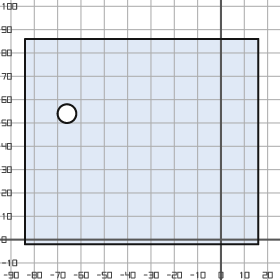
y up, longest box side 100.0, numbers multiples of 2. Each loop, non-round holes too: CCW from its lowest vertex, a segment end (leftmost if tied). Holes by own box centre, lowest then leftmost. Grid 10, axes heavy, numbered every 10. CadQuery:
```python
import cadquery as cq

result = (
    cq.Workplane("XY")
    .moveTo(-84.0, -2.0)
    .lineTo(16.0, -2.0)
    .lineTo(16.0, 86.0)
    .lineTo(-84.0, 86.0)
    .close()
    .moveTo(-66.0, 54.0)
    .circle(4.0)
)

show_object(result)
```